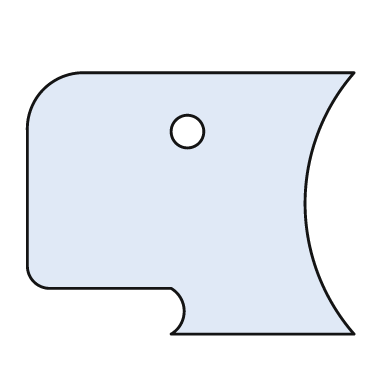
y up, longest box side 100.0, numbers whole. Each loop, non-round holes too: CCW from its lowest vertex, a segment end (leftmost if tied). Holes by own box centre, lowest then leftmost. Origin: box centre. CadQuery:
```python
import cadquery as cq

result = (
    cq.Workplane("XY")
    .moveTo(-6.0, -40.0)
    .lineTo(50.0, -40.0)
    .threePointArc((35.0, 0.0), (50.0, 40.0))
    .lineTo(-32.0, 40.0)
    .threePointArc((-45.0, 35.0), (-50.0, 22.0))
    .lineTo(-50.0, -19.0)
    .threePointArc((-48.0, -24.0), (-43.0, -26.0))
    .lineTo(-6.0, -26.0)
    .threePointArc((-2.0, -33.0), (-6.0, -40.0))
    .close()
    .moveTo(-1.0, 22.0)
    .circle(5.0)
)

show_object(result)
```